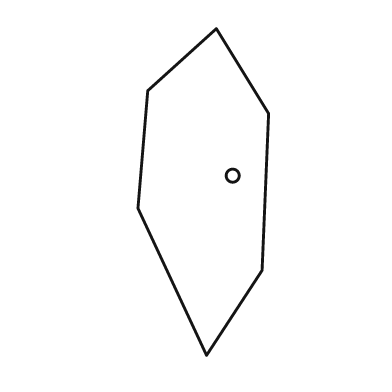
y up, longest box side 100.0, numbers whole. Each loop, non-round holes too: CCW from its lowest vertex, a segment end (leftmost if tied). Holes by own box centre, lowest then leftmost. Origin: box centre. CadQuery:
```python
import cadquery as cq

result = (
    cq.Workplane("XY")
    .moveTo(1.0, -50.0)
    .lineTo(18.0, -24.0)
    .lineTo(20.0, 24.0)
    .lineTo(4.0, 50.0)
    .lineTo(-17.0, 31.0)
    .lineTo(-20.0, -5.0)
    .close()
    .moveTo(9.0, 5.0)
    .circle(2.0)
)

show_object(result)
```